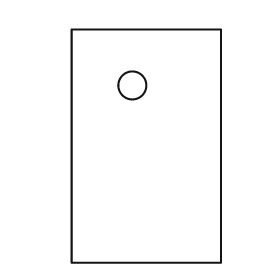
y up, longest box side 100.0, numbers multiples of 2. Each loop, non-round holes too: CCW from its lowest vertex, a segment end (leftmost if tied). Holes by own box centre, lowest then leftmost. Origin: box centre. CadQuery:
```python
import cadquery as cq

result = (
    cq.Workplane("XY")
    .moveTo(-32.0, -50.0)
    .lineTo(32.0, -50.0)
    .lineTo(32.0, 50.0)
    .lineTo(-32.0, 50.0)
    .close()
    .moveTo(-6.0, 26.0)
    .circle(6.0)
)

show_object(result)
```